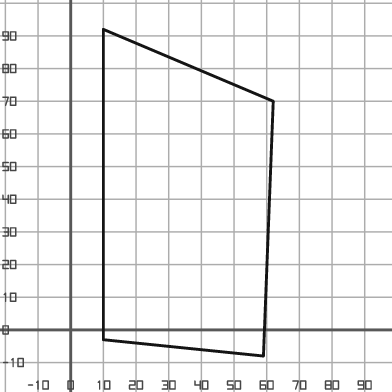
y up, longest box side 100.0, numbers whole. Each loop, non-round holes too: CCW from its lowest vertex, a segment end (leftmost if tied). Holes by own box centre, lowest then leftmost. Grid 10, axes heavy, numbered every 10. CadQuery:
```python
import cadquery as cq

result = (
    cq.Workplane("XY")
    .moveTo(59.0, -8.0)
    .lineTo(62.0, 70.0)
    .lineTo(10.0, 92.0)
    .lineTo(10.0, -3.0)
    .close()
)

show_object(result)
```